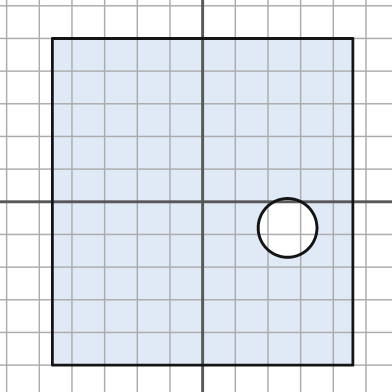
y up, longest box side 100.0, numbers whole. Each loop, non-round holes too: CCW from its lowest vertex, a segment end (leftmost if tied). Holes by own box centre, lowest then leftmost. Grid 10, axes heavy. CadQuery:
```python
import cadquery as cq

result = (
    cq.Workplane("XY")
    .moveTo(-46.0, -50.0)
    .lineTo(46.0, -50.0)
    .lineTo(46.0, 50.0)
    .lineTo(-46.0, 50.0)
    .close()
    .moveTo(26.0, -8.0)
    .circle(9.0)
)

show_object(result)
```